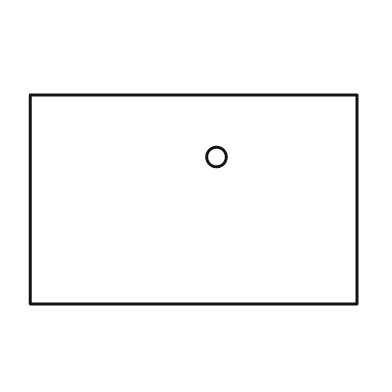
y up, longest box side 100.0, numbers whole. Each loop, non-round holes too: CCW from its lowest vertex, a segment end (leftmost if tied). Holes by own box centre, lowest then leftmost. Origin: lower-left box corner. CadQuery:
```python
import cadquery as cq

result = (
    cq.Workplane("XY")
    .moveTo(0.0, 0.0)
    .lineTo(100.0, 0.0)
    .lineTo(100.0, 64.0)
    .lineTo(0.0, 64.0)
    .close()
    .moveTo(57.0, 45.0)
    .circle(3.0)
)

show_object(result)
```